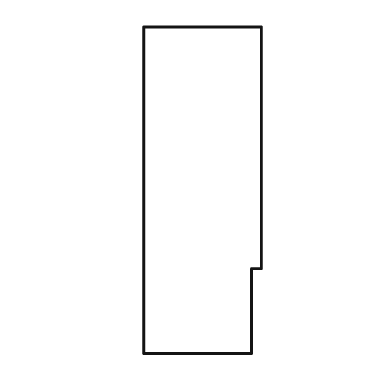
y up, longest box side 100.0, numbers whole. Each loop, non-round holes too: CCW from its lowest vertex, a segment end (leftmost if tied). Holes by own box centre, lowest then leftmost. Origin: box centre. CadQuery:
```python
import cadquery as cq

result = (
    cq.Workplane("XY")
    .moveTo(-18.0, -50.0)
    .lineTo(15.0, -50.0)
    .lineTo(15.0, -24.0)
    .lineTo(18.0, -24.0)
    .lineTo(18.0, 50.0)
    .lineTo(-18.0, 50.0)
    .close()
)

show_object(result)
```